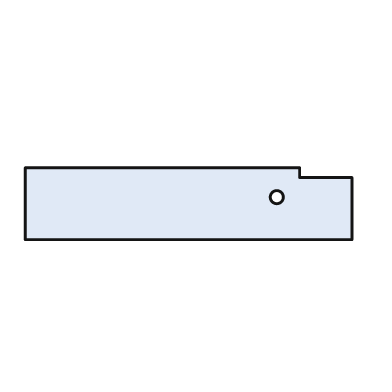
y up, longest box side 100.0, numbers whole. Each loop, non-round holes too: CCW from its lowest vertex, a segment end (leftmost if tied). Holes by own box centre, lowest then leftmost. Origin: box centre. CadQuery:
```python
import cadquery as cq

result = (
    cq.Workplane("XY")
    .moveTo(-50.0, -11.0)
    .lineTo(50.0, -11.0)
    .lineTo(50.0, 8.0)
    .lineTo(34.0, 8.0)
    .lineTo(34.0, 11.0)
    .lineTo(-50.0, 11.0)
    .close()
    .moveTo(27.0, 2.0)
    .circle(2.0)
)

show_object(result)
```